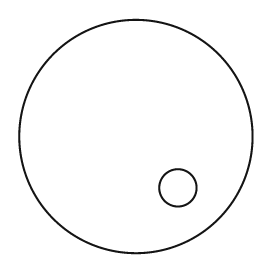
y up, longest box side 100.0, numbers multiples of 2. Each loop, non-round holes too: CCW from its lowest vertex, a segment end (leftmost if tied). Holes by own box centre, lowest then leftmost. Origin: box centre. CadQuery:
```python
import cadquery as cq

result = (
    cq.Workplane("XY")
    .moveTo(0.0, 0.0)
    .circle(50.0)
    .moveTo(18.0, -22.0)
    .circle(8.0)
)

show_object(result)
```